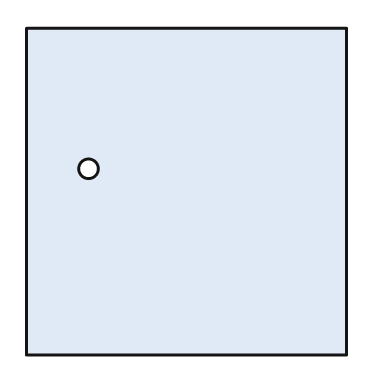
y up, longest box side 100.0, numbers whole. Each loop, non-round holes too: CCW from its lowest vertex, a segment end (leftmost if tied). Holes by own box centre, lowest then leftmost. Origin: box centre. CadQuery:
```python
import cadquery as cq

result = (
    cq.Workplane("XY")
    .moveTo(-49.0, -50.0)
    .lineTo(49.0, -50.0)
    .lineTo(49.0, 50.0)
    .lineTo(-49.0, 50.0)
    .close()
    .moveTo(-30.0, 7.0)
    .circle(3.0)
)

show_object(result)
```